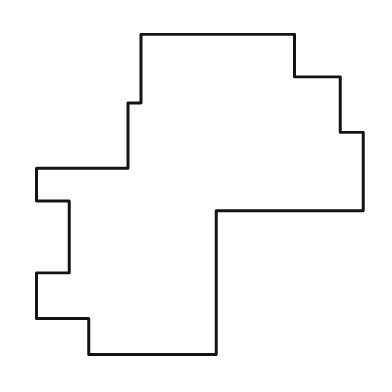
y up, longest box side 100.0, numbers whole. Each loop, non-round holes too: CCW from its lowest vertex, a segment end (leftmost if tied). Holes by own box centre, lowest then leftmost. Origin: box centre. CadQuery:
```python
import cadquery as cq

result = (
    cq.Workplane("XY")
    .moveTo(-34.0, -49.0)
    .lineTo(5.0, -49.0)
    .lineTo(5.0, -5.0)
    .lineTo(50.0, -5.0)
    .lineTo(50.0, 19.0)
    .lineTo(43.0, 19.0)
    .lineTo(43.0, 36.0)
    .lineTo(29.0, 36.0)
    .lineTo(29.0, 49.0)
    .lineTo(-18.0, 49.0)
    .lineTo(-18.0, 28.0)
    .lineTo(-22.0, 28.0)
    .lineTo(-22.0, 8.0)
    .lineTo(-50.0, 8.0)
    .lineTo(-50.0, -2.0)
    .lineTo(-40.0, -2.0)
    .lineTo(-40.0, -24.0)
    .lineTo(-50.0, -24.0)
    .lineTo(-50.0, -38.0)
    .lineTo(-34.0, -38.0)
    .close()
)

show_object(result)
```